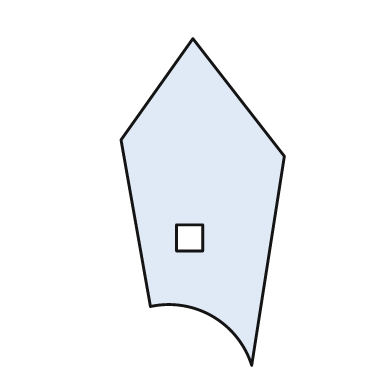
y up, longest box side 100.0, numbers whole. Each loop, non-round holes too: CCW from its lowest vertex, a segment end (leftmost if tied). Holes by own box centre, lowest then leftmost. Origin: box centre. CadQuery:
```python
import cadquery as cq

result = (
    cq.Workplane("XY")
    .moveTo(15.0, -50.0)
    .lineTo(25.0, 14.0)
    .lineTo(-3.0, 50.0)
    .lineTo(-25.0, 19.0)
    .lineTo(-16.0, -32.0)
    .threePointArc((3.0, -35.0), (15.0, -50.0))
    .close()
    .moveTo(-8.0, -15.0)
    .lineTo(0.0, -15.0)
    .lineTo(0.0, -7.0)
    .lineTo(-8.0, -7.0)
    .close()
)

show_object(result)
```